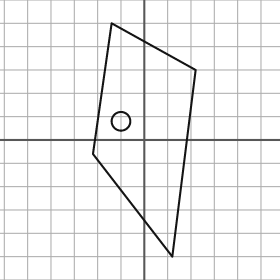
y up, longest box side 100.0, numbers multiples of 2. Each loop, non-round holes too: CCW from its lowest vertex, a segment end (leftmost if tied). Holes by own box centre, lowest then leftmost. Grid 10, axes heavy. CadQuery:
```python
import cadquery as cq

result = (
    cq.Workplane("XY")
    .moveTo(12.0, -50.0)
    .lineTo(22.0, 30.0)
    .lineTo(-14.0, 50.0)
    .lineTo(-22.0, -6.0)
    .close()
    .moveTo(-10.0, 8.0)
    .circle(4.0)
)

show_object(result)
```